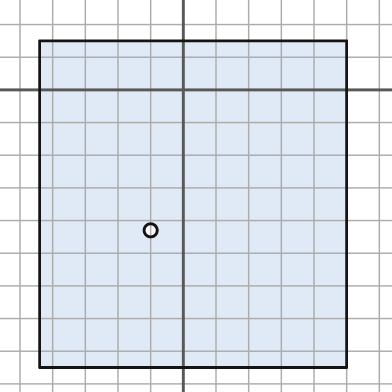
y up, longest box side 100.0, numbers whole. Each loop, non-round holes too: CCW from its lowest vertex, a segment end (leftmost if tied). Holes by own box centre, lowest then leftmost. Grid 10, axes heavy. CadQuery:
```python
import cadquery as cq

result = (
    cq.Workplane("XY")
    .moveTo(-44.0, -85.0)
    .lineTo(50.0, -85.0)
    .lineTo(50.0, 15.0)
    .lineTo(-44.0, 15.0)
    .close()
    .moveTo(-10.0, -43.0)
    .circle(2.0)
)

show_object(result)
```